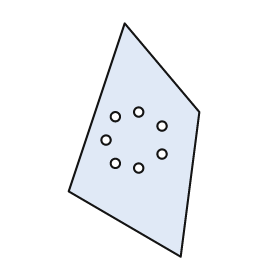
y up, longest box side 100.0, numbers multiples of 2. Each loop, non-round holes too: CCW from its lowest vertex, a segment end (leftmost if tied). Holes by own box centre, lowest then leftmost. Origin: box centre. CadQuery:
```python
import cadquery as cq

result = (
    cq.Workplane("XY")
    .moveTo(20.0, -50.0)
    .lineTo(28.0, 12.0)
    .lineTo(-4.0, 50.0)
    .lineTo(-28.0, -22.0)
    .close()
    .moveTo(2.0, -12.0)
    .circle(2.0)
    .moveTo(-8.0, -10.0)
    .circle(2.0)
    .moveTo(12.0, -6.0)
    .circle(2.0)
    .moveTo(-12.0, 0.0)
    .circle(2.0)
    .moveTo(12.0, 6.0)
    .circle(2.0)
    .moveTo(-8.0, 10.0)
    .circle(2.0)
    .moveTo(2.0, 12.0)
    .circle(2.0)
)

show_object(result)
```